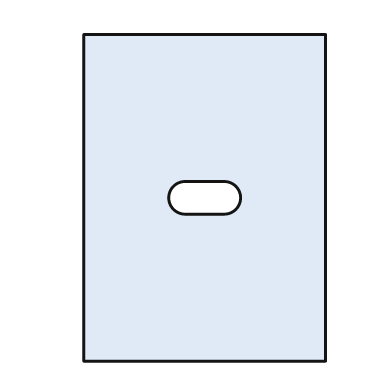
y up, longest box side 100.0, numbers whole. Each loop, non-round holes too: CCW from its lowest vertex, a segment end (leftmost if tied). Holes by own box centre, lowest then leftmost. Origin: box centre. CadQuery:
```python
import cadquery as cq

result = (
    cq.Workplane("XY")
    .moveTo(-37.0, -50.0)
    .lineTo(37.0, -50.0)
    .lineTo(37.0, 50.0)
    .lineTo(-37.0, 50.0)
    .close()
    .moveTo(-6.0, -5.0)
    .lineTo(6.0, -5.0)
    .threePointArc((11.0, 0.0), (6.0, 5.0))
    .lineTo(-6.0, 5.0)
    .threePointArc((-11.0, 0.0), (-6.0, -5.0))
    .close()
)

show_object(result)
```